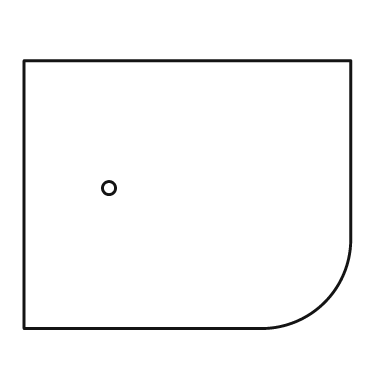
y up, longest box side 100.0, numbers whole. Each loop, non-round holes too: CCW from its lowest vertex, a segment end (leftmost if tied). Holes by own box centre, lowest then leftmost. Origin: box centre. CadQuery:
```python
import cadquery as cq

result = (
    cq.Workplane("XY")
    .moveTo(-50.0, -41.0)
    .lineTo(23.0, -41.0)
    .threePointArc((42.0, -33.0), (50.0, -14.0))
    .lineTo(50.0, 41.0)
    .lineTo(-50.0, 41.0)
    .close()
    .moveTo(-24.0, 2.0)
    .circle(2.0)
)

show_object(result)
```